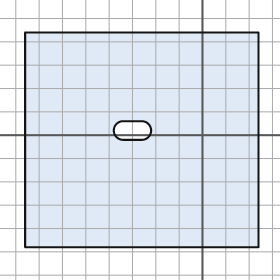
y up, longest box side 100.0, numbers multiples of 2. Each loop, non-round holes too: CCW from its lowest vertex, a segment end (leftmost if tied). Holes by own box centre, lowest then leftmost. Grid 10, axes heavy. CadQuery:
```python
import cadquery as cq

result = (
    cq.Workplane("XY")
    .moveTo(-76.0, -48.0)
    .lineTo(24.0, -48.0)
    .lineTo(24.0, 44.0)
    .lineTo(-76.0, 44.0)
    .close()
    .moveTo(-34.0, -2.0)
    .lineTo(-26.0, -2.0)
    .threePointArc((-22.0, 2.0), (-26.0, 6.0))
    .lineTo(-34.0, 6.0)
    .threePointArc((-38.0, 2.0), (-34.0, -2.0))
    .close()
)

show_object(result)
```